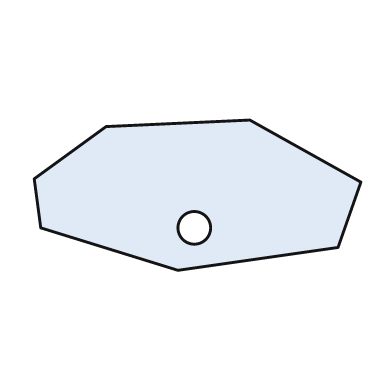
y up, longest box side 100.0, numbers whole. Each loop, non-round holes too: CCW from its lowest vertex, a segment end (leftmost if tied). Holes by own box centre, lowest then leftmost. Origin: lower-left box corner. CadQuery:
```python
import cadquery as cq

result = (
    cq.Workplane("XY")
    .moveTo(44.0, 0.0)
    .lineTo(93.0, 7.0)
    .lineTo(100.0, 27.0)
    .lineTo(66.0, 46.0)
    .lineTo(22.0, 44.0)
    .lineTo(0.0, 28.0)
    .lineTo(2.0, 13.0)
    .close()
    .moveTo(49.0, 13.0)
    .circle(5.0)
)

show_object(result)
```